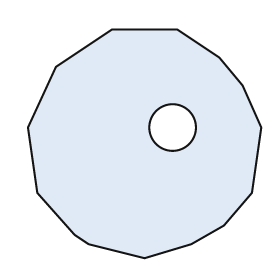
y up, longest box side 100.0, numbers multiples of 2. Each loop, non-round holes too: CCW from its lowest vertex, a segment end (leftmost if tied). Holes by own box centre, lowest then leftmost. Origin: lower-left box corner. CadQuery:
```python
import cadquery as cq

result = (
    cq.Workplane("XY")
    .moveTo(50.0, 0.0)
    .lineTo(70.0, 6.0)
    .lineTo(84.0, 14.0)
    .lineTo(96.0, 28.0)
    .lineTo(100.0, 56.0)
    .lineTo(92.0, 74.0)
    .lineTo(82.0, 86.0)
    .lineTo(64.0, 98.0)
    .lineTo(36.0, 98.0)
    .lineTo(12.0, 82.0)
    .lineTo(0.0, 56.0)
    .lineTo(4.0, 28.0)
    .lineTo(20.0, 10.0)
    .lineTo(26.0, 6.0)
    .close()
    .moveTo(62.0, 56.0)
    .circle(10.0)
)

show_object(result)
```